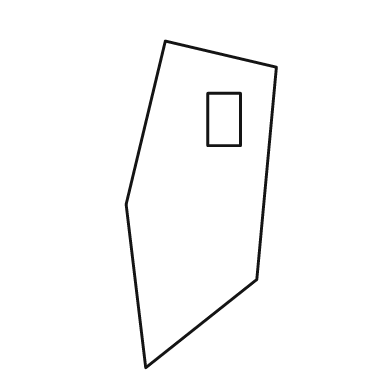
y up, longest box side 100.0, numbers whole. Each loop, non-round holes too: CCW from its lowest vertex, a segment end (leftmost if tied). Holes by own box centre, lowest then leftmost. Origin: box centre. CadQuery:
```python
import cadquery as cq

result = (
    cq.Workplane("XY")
    .moveTo(-17.0, -50.0)
    .lineTo(17.0, -23.0)
    .lineTo(23.0, 42.0)
    .lineTo(-11.0, 50.0)
    .lineTo(-23.0, 0.0)
    .close()
    .moveTo(2.0, 18.0)
    .lineTo(12.0, 18.0)
    .lineTo(12.0, 34.0)
    .lineTo(2.0, 34.0)
    .close()
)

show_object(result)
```